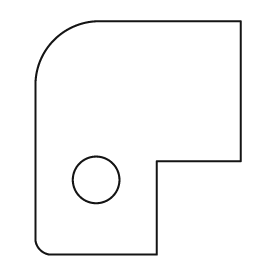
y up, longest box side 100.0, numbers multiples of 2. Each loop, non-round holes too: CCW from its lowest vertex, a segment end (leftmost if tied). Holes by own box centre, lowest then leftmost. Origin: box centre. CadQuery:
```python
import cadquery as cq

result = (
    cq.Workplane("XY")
    .moveTo(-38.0, -50.0)
    .lineTo(8.0, -50.0)
    .lineTo(8.0, -10.0)
    .lineTo(44.0, -10.0)
    .lineTo(44.0, 50.0)
    .lineTo(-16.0, 50.0)
    .threePointArc((-36.0, 42.0), (-44.0, 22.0))
    .lineTo(-44.0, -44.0)
    .threePointArc((-42.0, -48.0), (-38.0, -50.0))
    .close()
    .moveTo(-18.0, -18.0)
    .circle(10.0)
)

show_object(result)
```